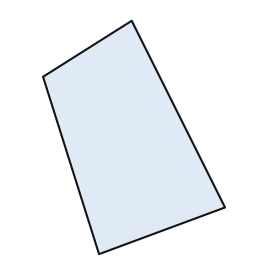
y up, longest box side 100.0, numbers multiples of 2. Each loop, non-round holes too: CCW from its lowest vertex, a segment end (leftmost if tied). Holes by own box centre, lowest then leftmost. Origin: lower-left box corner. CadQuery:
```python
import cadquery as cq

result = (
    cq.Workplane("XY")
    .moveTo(24.0, 0.0)
    .lineTo(78.0, 20.0)
    .lineTo(38.0, 100.0)
    .lineTo(0.0, 76.0)
    .close()
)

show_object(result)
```